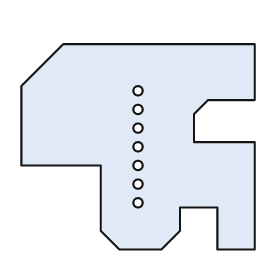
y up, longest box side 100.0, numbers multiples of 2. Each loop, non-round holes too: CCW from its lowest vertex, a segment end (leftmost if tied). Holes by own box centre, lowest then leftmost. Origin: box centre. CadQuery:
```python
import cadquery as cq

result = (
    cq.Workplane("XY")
    .moveTo(-8.0, -44.0)
    .lineTo(10.0, -44.0)
    .lineTo(18.0, -36.0)
    .lineTo(18.0, -26.0)
    .lineTo(34.0, -26.0)
    .lineTo(34.0, -44.0)
    .lineTo(50.0, -44.0)
    .lineTo(50.0, 2.0)
    .lineTo(24.0, 2.0)
    .lineTo(24.0, 14.0)
    .lineTo(30.0, 20.0)
    .lineTo(50.0, 20.0)
    .lineTo(50.0, 44.0)
    .lineTo(-32.0, 44.0)
    .lineTo(-50.0, 26.0)
    .lineTo(-50.0, -8.0)
    .lineTo(-16.0, -8.0)
    .lineTo(-16.0, -36.0)
    .close()
    .moveTo(0.0, -24.0)
    .circle(2.0)
    .moveTo(0.0, -16.0)
    .circle(2.0)
    .moveTo(0.0, -8.0)
    .circle(2.0)
    .moveTo(0.0, 0.0)
    .circle(2.0)
    .moveTo(0.0, 8.0)
    .circle(2.0)
    .moveTo(0.0, 16.0)
    .circle(2.0)
    .moveTo(0.0, 24.0)
    .circle(2.0)
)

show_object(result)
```